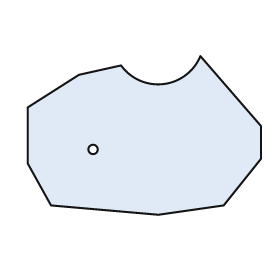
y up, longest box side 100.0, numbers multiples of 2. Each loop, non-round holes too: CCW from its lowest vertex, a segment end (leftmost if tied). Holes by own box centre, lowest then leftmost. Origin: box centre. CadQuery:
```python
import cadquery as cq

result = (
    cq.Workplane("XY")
    .moveTo(6.0, -34.0)
    .lineTo(34.0, -30.0)
    .lineTo(50.0, -10.0)
    .lineTo(50.0, 4.0)
    .lineTo(24.0, 34.0)
    .threePointArc((8.0, 22.0), (-10.0, 30.0))
    .lineTo(-28.0, 26.0)
    .lineTo(-50.0, 12.0)
    .lineTo(-50.0, -12.0)
    .lineTo(-40.0, -30.0)
    .close()
    .moveTo(-22.0, -6.0)
    .circle(2.0)
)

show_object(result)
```